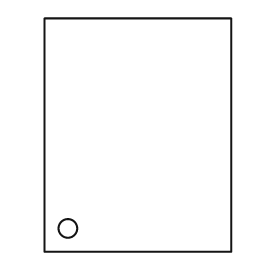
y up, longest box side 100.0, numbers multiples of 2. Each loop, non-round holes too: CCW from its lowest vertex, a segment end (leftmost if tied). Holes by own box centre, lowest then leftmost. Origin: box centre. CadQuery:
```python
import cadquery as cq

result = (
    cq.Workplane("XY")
    .moveTo(-40.0, -50.0)
    .lineTo(40.0, -50.0)
    .lineTo(40.0, 50.0)
    .lineTo(-40.0, 50.0)
    .close()
    .moveTo(-30.0, -40.0)
    .circle(4.0)
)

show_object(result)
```